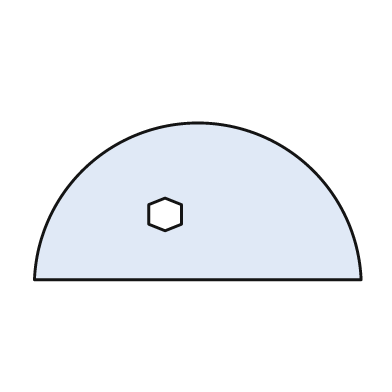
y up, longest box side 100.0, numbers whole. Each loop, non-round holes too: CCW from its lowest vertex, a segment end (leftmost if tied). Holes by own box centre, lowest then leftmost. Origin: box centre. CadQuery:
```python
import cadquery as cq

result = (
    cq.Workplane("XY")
    .moveTo(-50.0, -24.0)
    .lineTo(50.0, -24.0)
    .threePointArc((0.0, 24.0), (-50.0, -24.0))
    .close()
    .moveTo(-10.0, -9.0)
    .lineTo(-5.0, -7.0)
    .lineTo(-5.0, -1.0)
    .lineTo(-10.0, 1.0)
    .lineTo(-15.0, -1.0)
    .lineTo(-15.0, -7.0)
    .close()
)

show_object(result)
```